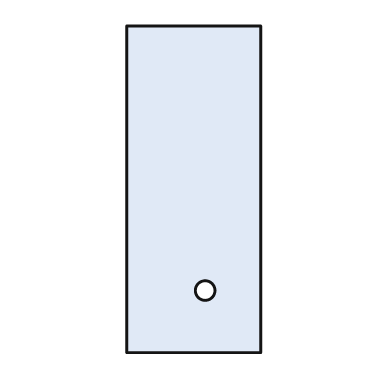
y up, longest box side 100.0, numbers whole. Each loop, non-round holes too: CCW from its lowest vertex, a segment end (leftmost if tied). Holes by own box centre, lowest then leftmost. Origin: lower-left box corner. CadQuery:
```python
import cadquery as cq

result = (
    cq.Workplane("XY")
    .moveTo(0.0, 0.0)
    .lineTo(41.0, 0.0)
    .lineTo(41.0, 100.0)
    .lineTo(0.0, 100.0)
    .close()
    .moveTo(24.0, 19.0)
    .circle(3.0)
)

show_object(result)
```